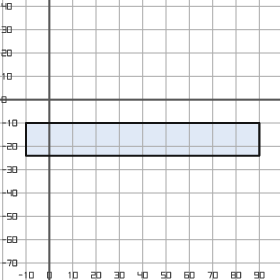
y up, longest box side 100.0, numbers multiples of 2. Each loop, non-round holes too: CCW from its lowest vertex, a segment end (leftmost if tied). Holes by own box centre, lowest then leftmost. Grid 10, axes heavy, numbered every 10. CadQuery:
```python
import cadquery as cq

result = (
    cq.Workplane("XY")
    .moveTo(-10.0, -24.0)
    .lineTo(90.0, -24.0)
    .lineTo(90.0, -10.0)
    .lineTo(-10.0, -10.0)
    .close()
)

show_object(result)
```